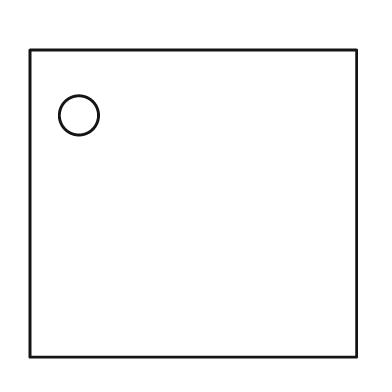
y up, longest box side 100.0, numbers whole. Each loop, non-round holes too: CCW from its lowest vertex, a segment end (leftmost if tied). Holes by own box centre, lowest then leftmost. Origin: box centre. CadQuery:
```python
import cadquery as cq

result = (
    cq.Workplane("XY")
    .moveTo(-50.0, -47.0)
    .lineTo(50.0, -47.0)
    .lineTo(50.0, 47.0)
    .lineTo(-50.0, 47.0)
    .close()
    .moveTo(-35.0, 27.0)
    .circle(6.0)
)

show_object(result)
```